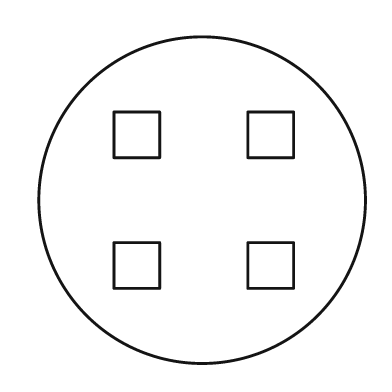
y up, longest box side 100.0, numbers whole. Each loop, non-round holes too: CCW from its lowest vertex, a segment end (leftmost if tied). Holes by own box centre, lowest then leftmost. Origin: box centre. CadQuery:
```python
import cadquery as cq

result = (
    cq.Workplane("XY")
    .moveTo(0.0, 0.0)
    .circle(50.0)
    .moveTo(-27.0, -27.0)
    .lineTo(-13.0, -27.0)
    .lineTo(-13.0, -13.0)
    .lineTo(-27.0, -13.0)
    .close()
    .moveTo(14.0, -27.0)
    .lineTo(28.0, -27.0)
    .lineTo(28.0, -13.0)
    .lineTo(14.0, -13.0)
    .close()
    .moveTo(-27.0, 13.0)
    .lineTo(-13.0, 13.0)
    .lineTo(-13.0, 27.0)
    .lineTo(-27.0, 27.0)
    .close()
    .moveTo(14.0, 13.0)
    .lineTo(28.0, 13.0)
    .lineTo(28.0, 27.0)
    .lineTo(14.0, 27.0)
    .close()
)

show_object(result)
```